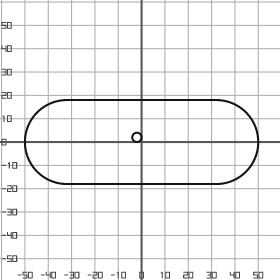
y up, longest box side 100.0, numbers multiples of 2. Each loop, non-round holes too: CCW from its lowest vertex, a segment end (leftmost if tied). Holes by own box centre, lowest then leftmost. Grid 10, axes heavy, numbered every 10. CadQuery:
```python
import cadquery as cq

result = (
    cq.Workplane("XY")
    .moveTo(-32.0, -18.0)
    .lineTo(32.0, -18.0)
    .threePointArc((50.0, 0.0), (32.0, 18.0))
    .lineTo(-32.0, 18.0)
    .threePointArc((-50.0, 0.0), (-32.0, -18.0))
    .close()
    .moveTo(-2.0, 2.0)
    .circle(2.0)
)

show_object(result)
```